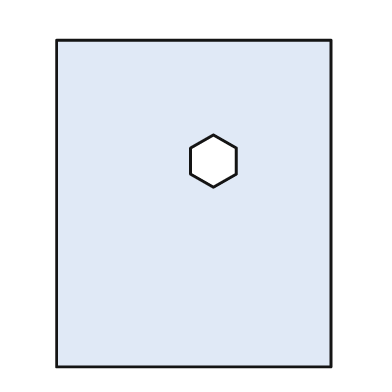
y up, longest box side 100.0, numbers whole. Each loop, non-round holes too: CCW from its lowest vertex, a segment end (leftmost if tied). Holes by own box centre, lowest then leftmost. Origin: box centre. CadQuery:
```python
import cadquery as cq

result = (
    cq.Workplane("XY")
    .moveTo(-42.0, -50.0)
    .lineTo(42.0, -50.0)
    .lineTo(42.0, 50.0)
    .lineTo(-42.0, 50.0)
    .close()
    .moveTo(6.0, 5.0)
    .lineTo(13.0, 9.0)
    .lineTo(13.0, 17.0)
    .lineTo(6.0, 21.0)
    .lineTo(-1.0, 17.0)
    .lineTo(-1.0, 9.0)
    .close()
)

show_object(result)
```